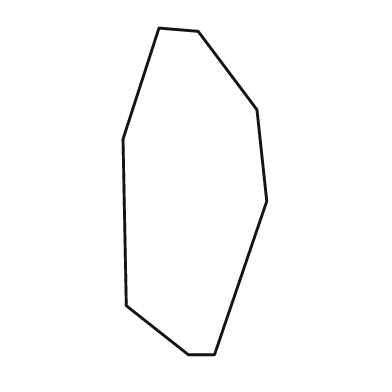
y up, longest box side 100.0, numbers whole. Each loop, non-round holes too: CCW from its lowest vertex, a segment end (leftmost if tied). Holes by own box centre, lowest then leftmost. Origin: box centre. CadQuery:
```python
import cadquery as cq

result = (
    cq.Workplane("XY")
    .moveTo(-2.0, -50.0)
    .lineTo(6.0, -50.0)
    .lineTo(22.0, -3.0)
    .lineTo(19.0, 25.0)
    .lineTo(1.0, 49.0)
    .lineTo(-11.0, 50.0)
    .lineTo(-22.0, 16.0)
    .lineTo(-21.0, -35.0)
    .close()
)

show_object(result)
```